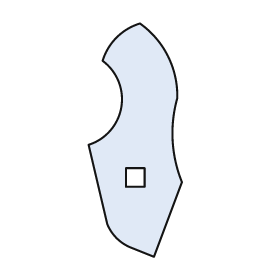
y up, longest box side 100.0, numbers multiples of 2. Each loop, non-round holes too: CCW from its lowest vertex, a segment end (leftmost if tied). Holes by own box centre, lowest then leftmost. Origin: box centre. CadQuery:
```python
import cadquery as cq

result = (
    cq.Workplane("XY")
    .moveTo(8.0, -50.0)
    .lineTo(20.0, -18.0)
    .threePointArc((16.0, 0.0), (18.0, 18.0))
    .threePointArc((14.0, 36.0), (2.0, 50.0))
    .threePointArc((-8.0, 44.0), (-14.0, 34.0))
    .threePointArc((-6.0, 14.0), (-20.0, -2.0))
    .lineTo(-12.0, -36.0)
    .threePointArc((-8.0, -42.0), (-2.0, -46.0))
    .close()
    .moveTo(-4.0, -20.0)
    .lineTo(4.0, -20.0)
    .lineTo(4.0, -12.0)
    .lineTo(-4.0, -12.0)
    .close()
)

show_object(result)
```